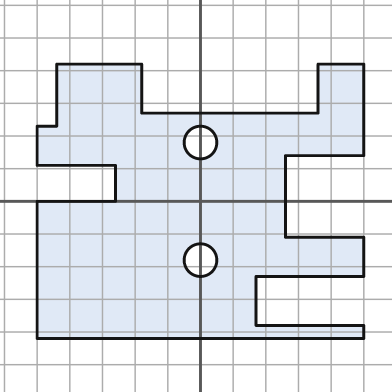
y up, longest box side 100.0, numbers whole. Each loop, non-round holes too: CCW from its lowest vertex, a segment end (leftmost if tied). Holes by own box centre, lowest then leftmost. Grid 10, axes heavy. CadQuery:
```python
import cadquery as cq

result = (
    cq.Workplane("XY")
    .moveTo(-50.0, -42.0)
    .lineTo(50.0, -42.0)
    .lineTo(50.0, -38.0)
    .lineTo(17.0, -38.0)
    .lineTo(17.0, -23.0)
    .lineTo(50.0, -23.0)
    .lineTo(50.0, -11.0)
    .lineTo(26.0, -11.0)
    .lineTo(26.0, 14.0)
    .lineTo(50.0, 14.0)
    .lineTo(50.0, 42.0)
    .lineTo(36.0, 42.0)
    .lineTo(36.0, 27.0)
    .lineTo(-18.0, 27.0)
    .lineTo(-18.0, 42.0)
    .lineTo(-44.0, 42.0)
    .lineTo(-44.0, 23.0)
    .lineTo(-50.0, 23.0)
    .lineTo(-50.0, 11.0)
    .lineTo(-26.0, 11.0)
    .lineTo(-26.0, 0.0)
    .lineTo(-50.0, 0.0)
    .close()
    .moveTo(0.0, -18.0)
    .circle(5.0)
    .moveTo(0.0, 18.0)
    .circle(5.0)
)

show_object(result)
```